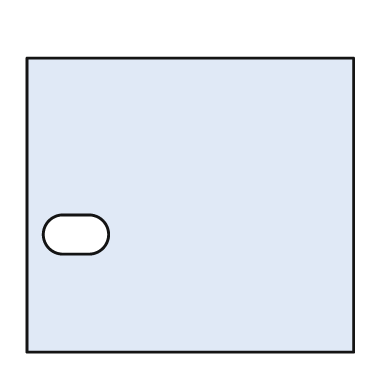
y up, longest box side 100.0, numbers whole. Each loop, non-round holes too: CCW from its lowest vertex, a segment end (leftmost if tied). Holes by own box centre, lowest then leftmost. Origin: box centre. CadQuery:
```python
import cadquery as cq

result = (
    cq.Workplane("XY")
    .moveTo(-50.0, -45.0)
    .lineTo(50.0, -45.0)
    .lineTo(50.0, 45.0)
    .lineTo(-50.0, 45.0)
    .close()
    .moveTo(-39.0, -15.0)
    .lineTo(-31.0, -15.0)
    .threePointArc((-25.0, -9.0), (-31.0, -3.0))
    .lineTo(-39.0, -3.0)
    .threePointArc((-45.0, -9.0), (-39.0, -15.0))
    .close()
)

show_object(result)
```